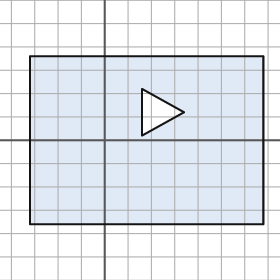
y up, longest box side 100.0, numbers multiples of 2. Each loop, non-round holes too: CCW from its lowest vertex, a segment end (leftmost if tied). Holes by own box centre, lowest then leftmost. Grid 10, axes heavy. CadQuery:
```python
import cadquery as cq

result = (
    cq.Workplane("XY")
    .moveTo(-32.0, -36.0)
    .lineTo(68.0, -36.0)
    .lineTo(68.0, 36.0)
    .lineTo(-32.0, 36.0)
    .close()
    .moveTo(16.0, 2.0)
    .lineTo(34.0, 12.0)
    .lineTo(16.0, 22.0)
    .close()
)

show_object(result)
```